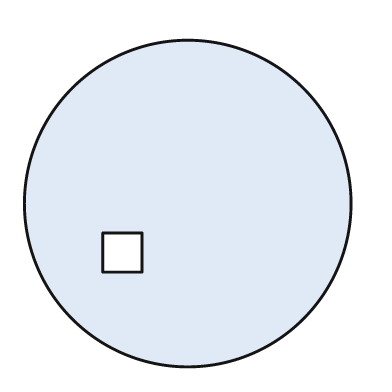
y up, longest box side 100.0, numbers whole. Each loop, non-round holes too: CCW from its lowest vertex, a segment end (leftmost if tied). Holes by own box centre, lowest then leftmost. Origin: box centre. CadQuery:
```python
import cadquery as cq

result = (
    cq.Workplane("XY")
    .moveTo(0.0, 0.0)
    .circle(50.0)
    .moveTo(-26.0, -21.0)
    .lineTo(-14.0, -21.0)
    .lineTo(-14.0, -9.0)
    .lineTo(-26.0, -9.0)
    .close()
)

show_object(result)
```